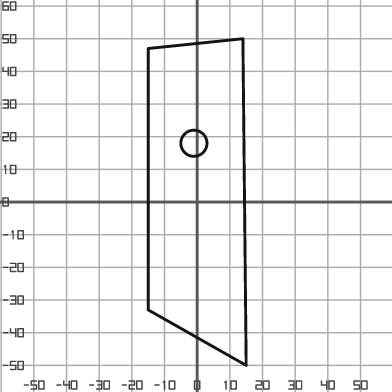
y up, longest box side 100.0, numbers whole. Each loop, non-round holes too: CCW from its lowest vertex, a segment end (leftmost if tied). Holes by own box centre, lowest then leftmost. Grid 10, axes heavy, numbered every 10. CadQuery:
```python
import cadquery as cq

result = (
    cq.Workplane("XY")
    .moveTo(15.0, -50.0)
    .lineTo(14.0, 50.0)
    .lineTo(-15.0, 47.0)
    .lineTo(-15.0, -33.0)
    .close()
    .moveTo(-1.0, 18.0)
    .circle(4.0)
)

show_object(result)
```